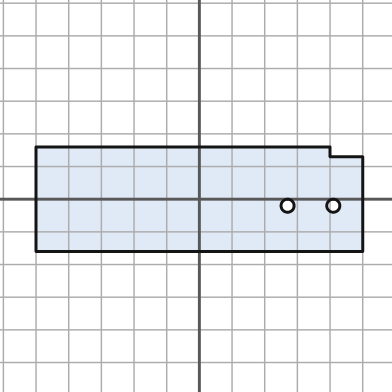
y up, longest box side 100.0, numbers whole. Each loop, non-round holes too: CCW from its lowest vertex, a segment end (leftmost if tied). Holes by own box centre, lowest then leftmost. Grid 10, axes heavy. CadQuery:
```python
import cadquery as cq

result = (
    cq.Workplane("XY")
    .moveTo(-50.0, -16.0)
    .lineTo(50.0, -16.0)
    .lineTo(50.0, 13.0)
    .lineTo(40.0, 13.0)
    .lineTo(40.0, 16.0)
    .lineTo(-50.0, 16.0)
    .close()
    .moveTo(27.0, -2.0)
    .circle(2.0)
    .moveTo(41.0, -2.0)
    .circle(2.0)
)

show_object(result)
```